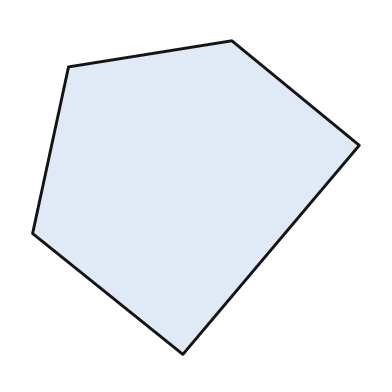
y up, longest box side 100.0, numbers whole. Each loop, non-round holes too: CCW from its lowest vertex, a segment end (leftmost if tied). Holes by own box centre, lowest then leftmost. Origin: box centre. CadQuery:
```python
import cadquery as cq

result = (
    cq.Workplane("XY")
    .moveTo(-4.0, -48.0)
    .lineTo(50.0, 16.0)
    .lineTo(11.0, 48.0)
    .lineTo(-39.0, 40.0)
    .lineTo(-50.0, -11.0)
    .close()
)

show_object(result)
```